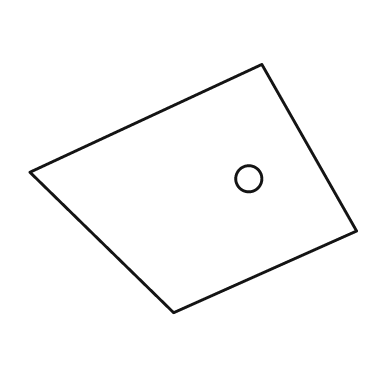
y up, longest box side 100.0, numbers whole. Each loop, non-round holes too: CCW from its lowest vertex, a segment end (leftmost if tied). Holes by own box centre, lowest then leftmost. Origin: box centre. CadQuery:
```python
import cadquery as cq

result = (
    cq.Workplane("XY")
    .moveTo(-6.0, -38.0)
    .lineTo(50.0, -13.0)
    .lineTo(21.0, 38.0)
    .lineTo(-50.0, 5.0)
    .close()
    .moveTo(17.0, 3.0)
    .circle(4.0)
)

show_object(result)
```